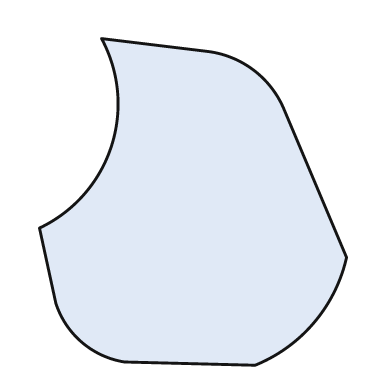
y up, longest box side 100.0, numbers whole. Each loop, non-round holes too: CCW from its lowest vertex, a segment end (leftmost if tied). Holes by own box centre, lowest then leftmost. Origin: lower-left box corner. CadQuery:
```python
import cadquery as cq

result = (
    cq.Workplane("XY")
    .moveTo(66.0, 0.0)
    .threePointArc((84.0, 13.0), (94.0, 33.0))
    .lineTo(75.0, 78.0)
    .threePointArc((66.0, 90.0), (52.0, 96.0))
    .lineTo(19.0, 100.0)
    .threePointArc((22.0, 67.0), (0.0, 42.0))
    .lineTo(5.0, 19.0)
    .threePointArc((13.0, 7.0), (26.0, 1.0))
    .close()
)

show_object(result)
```